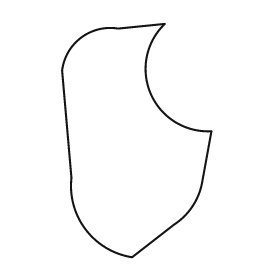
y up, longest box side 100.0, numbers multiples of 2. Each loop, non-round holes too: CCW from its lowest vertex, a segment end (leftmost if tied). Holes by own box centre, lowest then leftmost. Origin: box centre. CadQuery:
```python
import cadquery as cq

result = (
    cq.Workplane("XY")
    .moveTo(-2.0, -50.0)
    .lineTo(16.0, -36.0)
    .threePointArc((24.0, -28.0), (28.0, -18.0))
    .lineTo(32.0, 4.0)
    .threePointArc((6.0, 20.0), (12.0, 50.0))
    .lineTo(-8.0, 48.0)
    .threePointArc((-24.0, 44.0), (-32.0, 30.0))
    .lineTo(-28.0, -16.0)
    .threePointArc((-22.0, -38.0), (-2.0, -50.0))
    .close()
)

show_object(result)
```